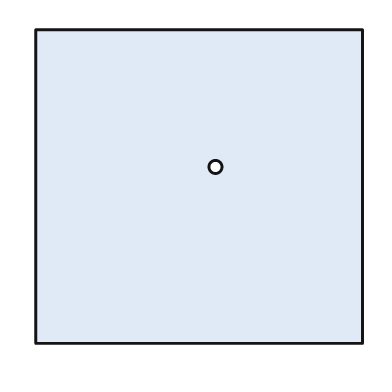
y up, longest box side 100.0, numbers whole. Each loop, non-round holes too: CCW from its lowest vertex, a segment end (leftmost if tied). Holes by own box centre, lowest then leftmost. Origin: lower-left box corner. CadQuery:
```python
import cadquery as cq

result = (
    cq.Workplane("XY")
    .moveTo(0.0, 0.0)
    .lineTo(100.0, 0.0)
    .lineTo(100.0, 96.0)
    .lineTo(0.0, 96.0)
    .close()
    .moveTo(55.0, 54.0)
    .circle(2.0)
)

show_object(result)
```